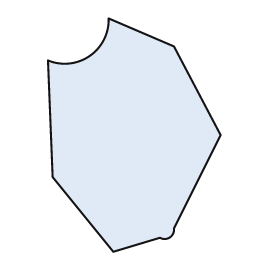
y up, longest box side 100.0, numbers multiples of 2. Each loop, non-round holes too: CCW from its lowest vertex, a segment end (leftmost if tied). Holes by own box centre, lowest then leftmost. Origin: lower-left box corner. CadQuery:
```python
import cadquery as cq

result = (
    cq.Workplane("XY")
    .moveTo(28.0, 0.0)
    .lineTo(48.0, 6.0)
    .threePointArc((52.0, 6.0), (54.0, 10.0))
    .lineTo(74.0, 50.0)
    .lineTo(54.0, 88.0)
    .lineTo(26.0, 100.0)
    .threePointArc((18.0, 84.0), (0.0, 82.0))
    .lineTo(2.0, 32.0)
    .close()
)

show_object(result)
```